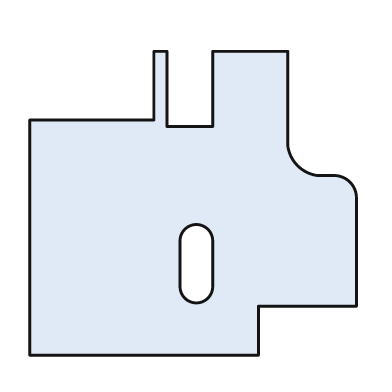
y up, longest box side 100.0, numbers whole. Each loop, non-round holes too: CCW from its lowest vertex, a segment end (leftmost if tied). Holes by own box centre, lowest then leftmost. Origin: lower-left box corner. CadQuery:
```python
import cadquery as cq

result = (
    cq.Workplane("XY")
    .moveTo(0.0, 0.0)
    .lineTo(70.0, 0.0)
    .lineTo(70.0, 15.0)
    .lineTo(100.0, 15.0)
    .lineTo(100.0, 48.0)
    .threePointArc((98.0, 53.0), (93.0, 55.0))
    .lineTo(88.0, 55.0)
    .threePointArc((82.0, 58.0), (79.0, 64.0))
    .lineTo(79.0, 93.0)
    .lineTo(56.0, 93.0)
    .lineTo(56.0, 70.0)
    .lineTo(42.0, 70.0)
    .lineTo(42.0, 93.0)
    .lineTo(38.0, 93.0)
    .lineTo(38.0, 72.0)
    .lineTo(0.0, 72.0)
    .close()
    .moveTo(46.0, 21.0)
    .threePointArc((51.0, 16.0), (56.0, 21.0))
    .lineTo(56.0, 35.0)
    .threePointArc((51.0, 40.0), (46.0, 35.0))
    .close()
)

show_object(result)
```